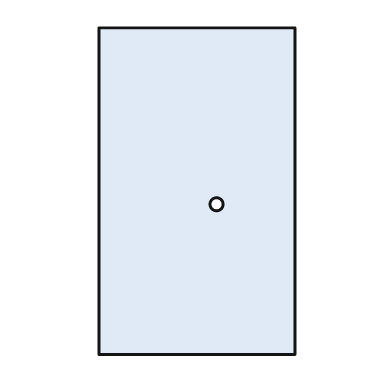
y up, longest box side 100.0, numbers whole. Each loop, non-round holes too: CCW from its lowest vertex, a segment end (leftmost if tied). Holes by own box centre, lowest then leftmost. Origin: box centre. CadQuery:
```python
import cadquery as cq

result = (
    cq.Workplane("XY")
    .moveTo(-30.0, -50.0)
    .lineTo(30.0, -50.0)
    .lineTo(30.0, 50.0)
    .lineTo(-30.0, 50.0)
    .close()
    .moveTo(6.0, -4.0)
    .circle(2.0)
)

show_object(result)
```